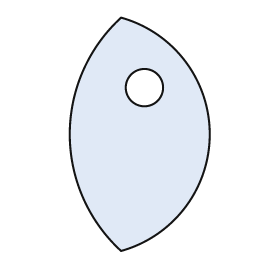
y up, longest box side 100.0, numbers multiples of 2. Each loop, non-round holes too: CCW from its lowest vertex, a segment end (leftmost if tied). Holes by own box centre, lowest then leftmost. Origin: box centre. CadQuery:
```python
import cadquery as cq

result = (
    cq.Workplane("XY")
    .moveTo(-8.0, -50.0)
    .threePointArc((30.0, 0.0), (-8.0, 50.0))
    .threePointArc((-30.0, 0.0), (-8.0, -50.0))
    .close()
    .moveTo(2.0, 20.0)
    .circle(8.0)
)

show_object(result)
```